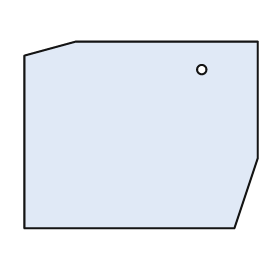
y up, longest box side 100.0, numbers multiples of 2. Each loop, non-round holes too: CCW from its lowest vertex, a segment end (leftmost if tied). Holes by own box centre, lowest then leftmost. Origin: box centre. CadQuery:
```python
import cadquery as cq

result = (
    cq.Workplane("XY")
    .moveTo(-50.0, -40.0)
    .lineTo(40.0, -40.0)
    .lineTo(50.0, -10.0)
    .lineTo(50.0, 40.0)
    .lineTo(-28.0, 40.0)
    .lineTo(-50.0, 34.0)
    .close()
    .moveTo(26.0, 28.0)
    .circle(2.0)
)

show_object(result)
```